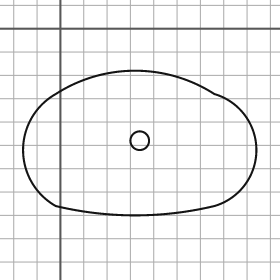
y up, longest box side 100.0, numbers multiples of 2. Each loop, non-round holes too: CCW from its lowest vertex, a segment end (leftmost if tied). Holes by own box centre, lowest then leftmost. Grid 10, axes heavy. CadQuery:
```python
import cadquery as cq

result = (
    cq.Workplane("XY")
    .moveTo(-2.0, -76.0)
    .threePointArc((32.0, -80.0), (66.0, -76.0))
    .threePointArc((84.0, -52.0), (66.0, -28.0))
    .threePointArc((32.0, -18.0), (-2.0, -28.0))
    .threePointArc((-16.0, -52.0), (-2.0, -76.0))
    .close()
    .moveTo(34.0, -48.0)
    .circle(4.0)
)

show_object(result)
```